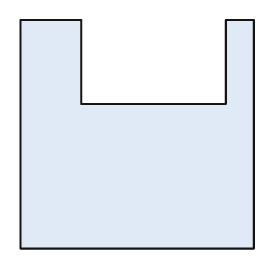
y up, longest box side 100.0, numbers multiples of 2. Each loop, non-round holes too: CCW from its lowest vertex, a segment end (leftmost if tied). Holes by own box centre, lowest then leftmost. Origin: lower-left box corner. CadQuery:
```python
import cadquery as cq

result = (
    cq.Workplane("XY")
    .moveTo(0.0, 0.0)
    .lineTo(100.0, 0.0)
    .lineTo(100.0, 98.0)
    .lineTo(88.0, 98.0)
    .lineTo(88.0, 62.0)
    .lineTo(26.0, 62.0)
    .lineTo(26.0, 98.0)
    .lineTo(0.0, 98.0)
    .close()
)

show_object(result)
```